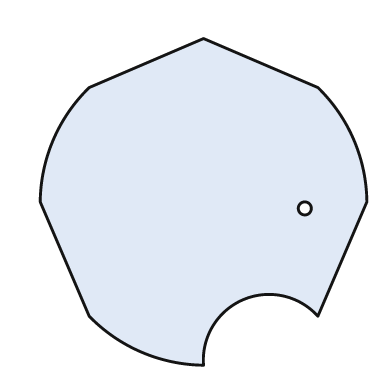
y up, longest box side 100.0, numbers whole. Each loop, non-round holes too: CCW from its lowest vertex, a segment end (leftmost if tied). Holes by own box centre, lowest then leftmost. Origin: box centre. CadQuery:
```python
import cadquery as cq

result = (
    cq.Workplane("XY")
    .moveTo(0.0, -50.0)
    .threePointArc((12.0, -30.0), (35.0, -35.0))
    .lineTo(50.0, 0.0)
    .threePointArc((46.0, 19.0), (35.0, 35.0))
    .lineTo(0.0, 50.0)
    .lineTo(-35.0, 35.0)
    .threePointArc((-46.0, 19.0), (-50.0, 0.0))
    .lineTo(-35.0, -35.0)
    .threePointArc((-19.0, -46.0), (0.0, -50.0))
    .close()
    .moveTo(31.0, -2.0)
    .circle(2.0)
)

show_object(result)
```